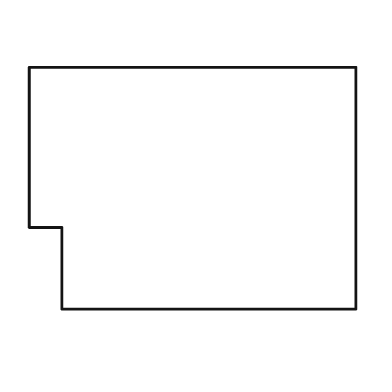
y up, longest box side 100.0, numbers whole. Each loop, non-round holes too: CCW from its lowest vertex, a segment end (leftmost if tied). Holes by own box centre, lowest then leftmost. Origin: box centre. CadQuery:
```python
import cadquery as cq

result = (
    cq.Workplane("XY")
    .moveTo(-40.0, -37.0)
    .lineTo(50.0, -37.0)
    .lineTo(50.0, 37.0)
    .lineTo(-50.0, 37.0)
    .lineTo(-50.0, -12.0)
    .lineTo(-40.0, -12.0)
    .close()
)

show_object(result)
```